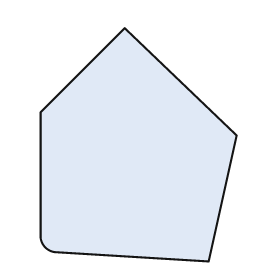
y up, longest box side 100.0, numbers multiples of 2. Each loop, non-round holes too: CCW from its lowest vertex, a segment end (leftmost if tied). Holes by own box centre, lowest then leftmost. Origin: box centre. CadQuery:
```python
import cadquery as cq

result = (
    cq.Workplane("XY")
    .moveTo(30.0, -50.0)
    .lineTo(42.0, 4.0)
    .lineTo(-6.0, 50.0)
    .lineTo(-42.0, 14.0)
    .lineTo(-42.0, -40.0)
    .threePointArc((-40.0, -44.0), (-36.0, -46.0))
    .close()
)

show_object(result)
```